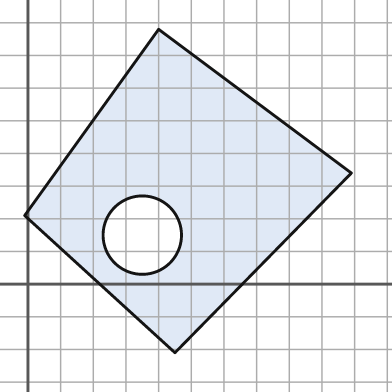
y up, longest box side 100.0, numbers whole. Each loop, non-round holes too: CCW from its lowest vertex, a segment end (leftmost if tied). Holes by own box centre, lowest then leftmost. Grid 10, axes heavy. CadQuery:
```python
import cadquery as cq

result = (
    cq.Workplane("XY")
    .moveTo(45.0, -21.0)
    .lineTo(99.0, 34.0)
    .lineTo(40.0, 78.0)
    .lineTo(-1.0, 21.0)
    .close()
    .moveTo(35.0, 15.0)
    .circle(12.0)
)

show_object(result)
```